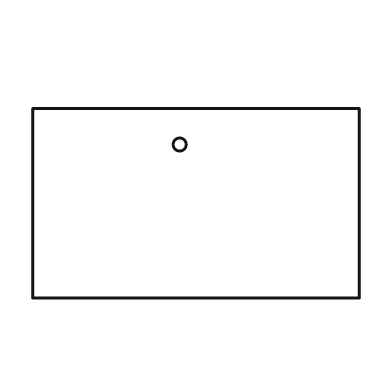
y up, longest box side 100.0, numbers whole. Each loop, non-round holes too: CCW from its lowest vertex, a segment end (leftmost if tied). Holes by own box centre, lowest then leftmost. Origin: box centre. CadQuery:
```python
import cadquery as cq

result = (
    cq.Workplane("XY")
    .moveTo(-50.0, -29.0)
    .lineTo(50.0, -29.0)
    .lineTo(50.0, 29.0)
    .lineTo(-50.0, 29.0)
    .close()
    .moveTo(-5.0, 18.0)
    .circle(2.0)
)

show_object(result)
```